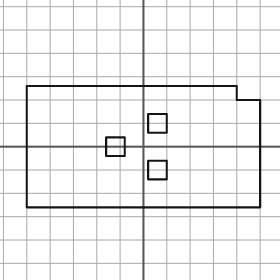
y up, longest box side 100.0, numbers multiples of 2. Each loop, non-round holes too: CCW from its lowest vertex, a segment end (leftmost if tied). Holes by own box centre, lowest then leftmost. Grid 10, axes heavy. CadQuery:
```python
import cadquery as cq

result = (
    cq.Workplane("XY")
    .moveTo(-50.0, -26.0)
    .lineTo(50.0, -26.0)
    .lineTo(50.0, 20.0)
    .lineTo(40.0, 20.0)
    .lineTo(40.0, 26.0)
    .lineTo(-50.0, 26.0)
    .close()
    .moveTo(2.0, -14.0)
    .lineTo(10.0, -14.0)
    .lineTo(10.0, -6.0)
    .lineTo(2.0, -6.0)
    .close()
    .moveTo(-16.0, -4.0)
    .lineTo(-8.0, -4.0)
    .lineTo(-8.0, 4.0)
    .lineTo(-16.0, 4.0)
    .close()
    .moveTo(2.0, 6.0)
    .lineTo(10.0, 6.0)
    .lineTo(10.0, 14.0)
    .lineTo(2.0, 14.0)
    .close()
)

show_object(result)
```